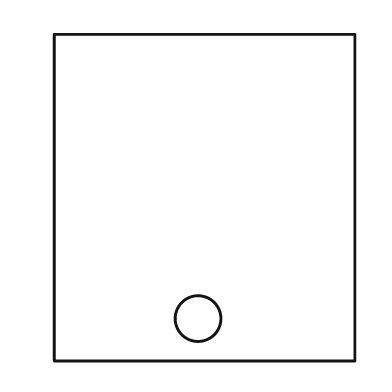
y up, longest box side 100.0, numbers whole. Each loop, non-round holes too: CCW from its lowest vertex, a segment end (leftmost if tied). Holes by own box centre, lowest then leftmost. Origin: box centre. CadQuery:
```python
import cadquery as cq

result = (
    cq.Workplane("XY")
    .moveTo(-46.0, -50.0)
    .lineTo(46.0, -50.0)
    .lineTo(46.0, 50.0)
    .lineTo(-46.0, 50.0)
    .close()
    .moveTo(-2.0, -37.0)
    .circle(7.0)
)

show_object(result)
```